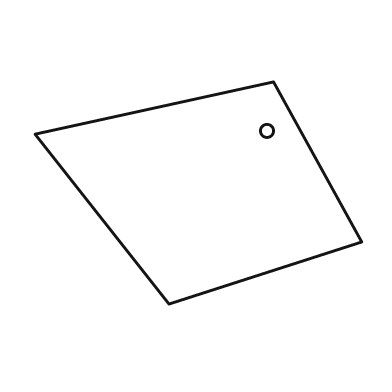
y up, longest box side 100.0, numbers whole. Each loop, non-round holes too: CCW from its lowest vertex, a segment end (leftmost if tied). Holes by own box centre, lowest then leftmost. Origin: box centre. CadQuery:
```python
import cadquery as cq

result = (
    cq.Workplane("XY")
    .moveTo(-9.0, -34.0)
    .lineTo(50.0, -15.0)
    .lineTo(23.0, 34.0)
    .lineTo(-50.0, 18.0)
    .close()
    .moveTo(21.0, 19.0)
    .circle(2.0)
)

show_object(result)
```